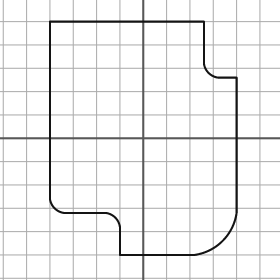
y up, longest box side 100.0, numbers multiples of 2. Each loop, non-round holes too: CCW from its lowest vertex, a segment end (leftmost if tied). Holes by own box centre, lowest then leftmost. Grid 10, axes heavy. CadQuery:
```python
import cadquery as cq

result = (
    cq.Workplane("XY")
    .moveTo(-10.0, -50.0)
    .lineTo(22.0, -50.0)
    .threePointArc((34.0, -44.0), (40.0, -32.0))
    .lineTo(40.0, 26.0)
    .lineTo(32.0, 26.0)
    .threePointArc((28.0, 28.0), (26.0, 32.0))
    .lineTo(26.0, 50.0)
    .lineTo(-40.0, 50.0)
    .lineTo(-40.0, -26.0)
    .threePointArc((-38.0, -30.0), (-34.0, -32.0))
    .lineTo(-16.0, -32.0)
    .threePointArc((-12.0, -34.0), (-10.0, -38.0))
    .close()
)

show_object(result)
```